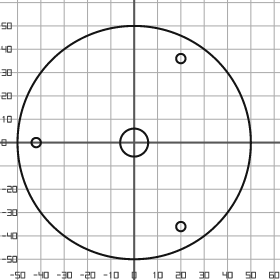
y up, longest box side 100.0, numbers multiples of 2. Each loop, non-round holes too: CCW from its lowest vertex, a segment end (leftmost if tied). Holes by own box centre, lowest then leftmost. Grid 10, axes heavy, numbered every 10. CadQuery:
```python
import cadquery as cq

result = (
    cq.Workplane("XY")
    .moveTo(0.0, 0.0)
    .circle(50.0)
    .moveTo(20.0, -36.0)
    .circle(2.0)
    .moveTo(-42.0, 0.0)
    .circle(2.0)
    .moveTo(0.0, 0.0)
    .circle(6.0)
    .moveTo(20.0, 36.0)
    .circle(2.0)
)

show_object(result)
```